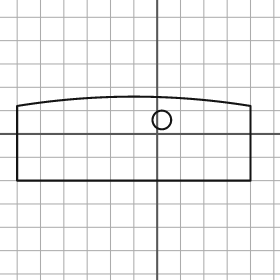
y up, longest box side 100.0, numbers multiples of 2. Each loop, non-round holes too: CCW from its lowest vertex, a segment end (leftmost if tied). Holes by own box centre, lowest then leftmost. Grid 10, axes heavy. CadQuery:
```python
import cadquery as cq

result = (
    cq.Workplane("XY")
    .moveTo(-60.0, -20.0)
    .lineTo(40.0, -20.0)
    .lineTo(40.0, 12.0)
    .threePointArc((-10.0, 16.0), (-60.0, 12.0))
    .close()
    .moveTo(2.0, 6.0)
    .circle(4.0)
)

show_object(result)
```